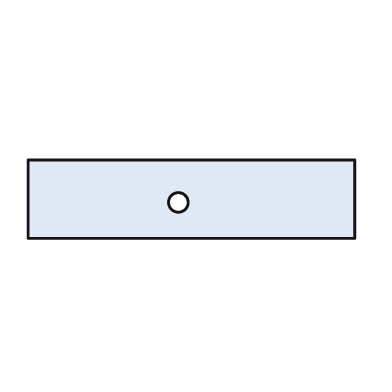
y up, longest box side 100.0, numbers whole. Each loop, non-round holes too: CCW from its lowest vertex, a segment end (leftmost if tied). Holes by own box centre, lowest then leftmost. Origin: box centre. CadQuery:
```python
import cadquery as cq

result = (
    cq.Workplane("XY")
    .moveTo(-50.0, -12.0)
    .lineTo(50.0, -12.0)
    .lineTo(50.0, 12.0)
    .lineTo(-50.0, 12.0)
    .close()
    .moveTo(-4.0, -1.0)
    .circle(3.0)
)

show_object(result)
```